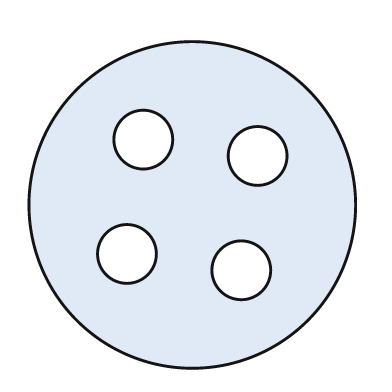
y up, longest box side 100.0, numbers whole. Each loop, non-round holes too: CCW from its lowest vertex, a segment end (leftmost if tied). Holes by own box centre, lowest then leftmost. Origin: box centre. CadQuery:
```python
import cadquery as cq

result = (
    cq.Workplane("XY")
    .moveTo(0.0, 0.0)
    .circle(50.0)
    .moveTo(15.0, -20.0)
    .circle(9.0)
    .moveTo(-20.0, -15.0)
    .circle(9.0)
    .moveTo(20.0, 15.0)
    .circle(9.0)
    .moveTo(-15.0, 20.0)
    .circle(9.0)
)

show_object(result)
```